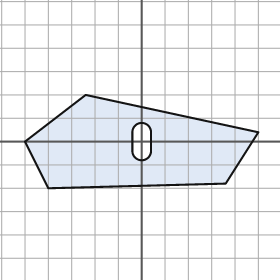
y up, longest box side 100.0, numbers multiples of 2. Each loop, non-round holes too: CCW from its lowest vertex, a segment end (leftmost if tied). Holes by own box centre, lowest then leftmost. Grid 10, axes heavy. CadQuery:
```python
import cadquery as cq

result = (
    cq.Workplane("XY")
    .moveTo(-40.0, -20.0)
    .lineTo(36.0, -18.0)
    .lineTo(50.0, 4.0)
    .lineTo(-24.0, 20.0)
    .lineTo(-50.0, 0.0)
    .close()
    .moveTo(-4.0, -4.0)
    .threePointArc((0.0, -8.0), (4.0, -4.0))
    .lineTo(4.0, 4.0)
    .threePointArc((0.0, 8.0), (-4.0, 4.0))
    .close()
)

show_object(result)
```